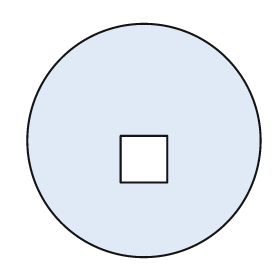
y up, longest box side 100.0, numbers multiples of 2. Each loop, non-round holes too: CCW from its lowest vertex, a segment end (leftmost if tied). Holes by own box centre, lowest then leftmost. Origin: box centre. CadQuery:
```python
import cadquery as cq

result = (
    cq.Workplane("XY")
    .moveTo(0.0, 0.0)
    .circle(50.0)
    .moveTo(-10.0, -18.0)
    .lineTo(10.0, -18.0)
    .lineTo(10.0, 2.0)
    .lineTo(-10.0, 2.0)
    .close()
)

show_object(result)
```